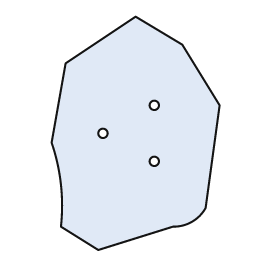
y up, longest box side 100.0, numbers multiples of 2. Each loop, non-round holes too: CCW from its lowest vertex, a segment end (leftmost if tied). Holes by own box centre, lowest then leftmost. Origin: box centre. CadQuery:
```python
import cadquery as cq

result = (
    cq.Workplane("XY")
    .moveTo(-16.0, -50.0)
    .lineTo(16.0, -40.0)
    .threePointArc((24.0, -38.0), (30.0, -32.0))
    .lineTo(36.0, 12.0)
    .lineTo(20.0, 38.0)
    .lineTo(0.0, 50.0)
    .lineTo(-30.0, 30.0)
    .lineTo(-36.0, -4.0)
    .threePointArc((-32.0, -22.0), (-32.0, -40.0))
    .close()
    .moveTo(8.0, -12.0)
    .circle(2.0)
    .moveTo(-14.0, 0.0)
    .circle(2.0)
    .moveTo(8.0, 12.0)
    .circle(2.0)
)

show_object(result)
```